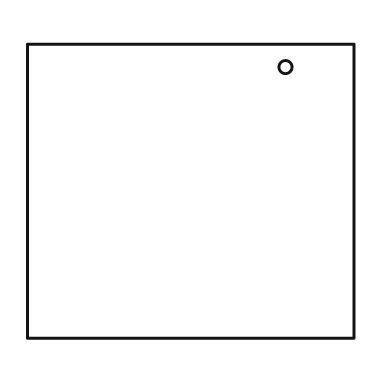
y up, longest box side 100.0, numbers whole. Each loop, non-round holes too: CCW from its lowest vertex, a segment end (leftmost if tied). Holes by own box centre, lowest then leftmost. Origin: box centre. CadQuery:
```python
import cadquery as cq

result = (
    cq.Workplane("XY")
    .moveTo(-50.0, -45.0)
    .lineTo(50.0, -45.0)
    .lineTo(50.0, 45.0)
    .lineTo(-50.0, 45.0)
    .close()
    .moveTo(29.0, 38.0)
    .circle(2.0)
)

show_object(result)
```